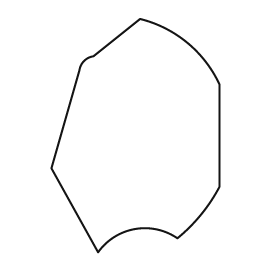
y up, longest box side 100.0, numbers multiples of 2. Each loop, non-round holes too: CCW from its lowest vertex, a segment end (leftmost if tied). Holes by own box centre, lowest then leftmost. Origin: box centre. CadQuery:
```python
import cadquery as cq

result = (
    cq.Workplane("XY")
    .moveTo(-16.0, -50.0)
    .threePointArc((0.0, -40.0), (18.0, -44.0))
    .threePointArc((28.0, -34.0), (36.0, -22.0))
    .lineTo(36.0, 22.0)
    .threePointArc((22.0, 40.0), (2.0, 50.0))
    .lineTo(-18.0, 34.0)
    .threePointArc((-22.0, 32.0), (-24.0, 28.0))
    .lineTo(-36.0, -14.0)
    .close()
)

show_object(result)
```